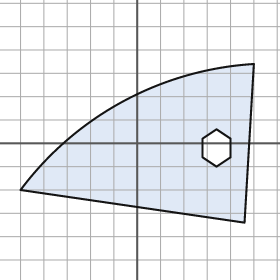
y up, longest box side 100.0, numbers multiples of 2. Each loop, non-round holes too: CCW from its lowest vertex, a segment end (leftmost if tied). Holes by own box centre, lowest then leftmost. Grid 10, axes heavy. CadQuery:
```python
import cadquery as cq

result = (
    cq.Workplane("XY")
    .moveTo(46.0, -34.0)
    .lineTo(50.0, 34.0)
    .threePointArc((-6.0, 18.0), (-50.0, -20.0))
    .close()
    .moveTo(34.0, -10.0)
    .lineTo(40.0, -6.0)
    .lineTo(40.0, 2.0)
    .lineTo(34.0, 6.0)
    .lineTo(28.0, 2.0)
    .lineTo(28.0, -6.0)
    .close()
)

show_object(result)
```